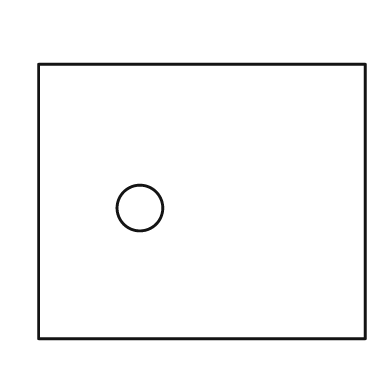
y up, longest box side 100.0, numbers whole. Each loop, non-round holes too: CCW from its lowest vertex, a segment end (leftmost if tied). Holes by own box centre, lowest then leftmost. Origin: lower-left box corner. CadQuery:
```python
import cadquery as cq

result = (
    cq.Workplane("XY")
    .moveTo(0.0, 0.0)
    .lineTo(100.0, 0.0)
    .lineTo(100.0, 84.0)
    .lineTo(0.0, 84.0)
    .close()
    .moveTo(31.0, 40.0)
    .circle(7.0)
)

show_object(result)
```